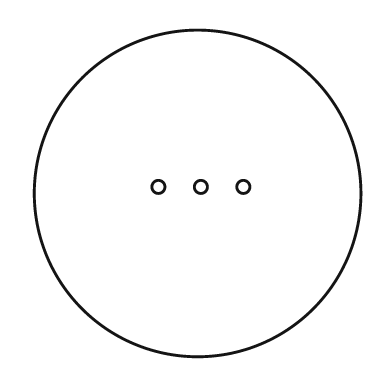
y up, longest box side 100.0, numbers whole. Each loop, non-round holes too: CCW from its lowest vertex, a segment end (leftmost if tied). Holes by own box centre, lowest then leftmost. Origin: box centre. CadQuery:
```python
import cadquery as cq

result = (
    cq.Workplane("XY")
    .moveTo(0.0, 0.0)
    .circle(50.0)
    .moveTo(-12.0, 2.0)
    .circle(2.0)
    .moveTo(1.0, 2.0)
    .circle(2.0)
    .moveTo(14.0, 2.0)
    .circle(2.0)
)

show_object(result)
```